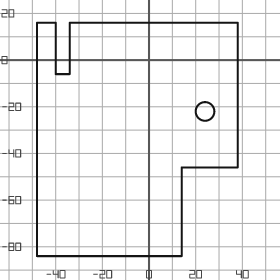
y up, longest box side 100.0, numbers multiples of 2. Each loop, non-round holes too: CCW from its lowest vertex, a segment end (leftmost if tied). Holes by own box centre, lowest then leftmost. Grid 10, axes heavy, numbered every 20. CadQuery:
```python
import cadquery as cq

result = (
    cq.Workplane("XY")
    .moveTo(-48.0, -84.0)
    .lineTo(14.0, -84.0)
    .lineTo(14.0, -46.0)
    .lineTo(38.0, -46.0)
    .lineTo(38.0, 16.0)
    .lineTo(-34.0, 16.0)
    .lineTo(-34.0, -6.0)
    .lineTo(-40.0, -6.0)
    .lineTo(-40.0, 16.0)
    .lineTo(-48.0, 16.0)
    .close()
    .moveTo(24.0, -22.0)
    .circle(4.0)
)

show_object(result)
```